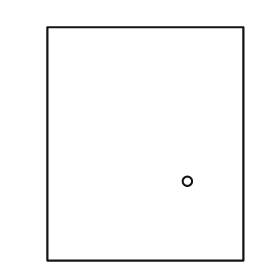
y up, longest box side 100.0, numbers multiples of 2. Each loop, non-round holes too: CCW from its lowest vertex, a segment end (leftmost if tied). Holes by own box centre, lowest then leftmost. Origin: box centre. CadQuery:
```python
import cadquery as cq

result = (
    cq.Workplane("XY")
    .moveTo(-42.0, -50.0)
    .lineTo(42.0, -50.0)
    .lineTo(42.0, 50.0)
    .lineTo(-42.0, 50.0)
    .close()
    .moveTo(18.0, -16.0)
    .circle(2.0)
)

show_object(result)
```